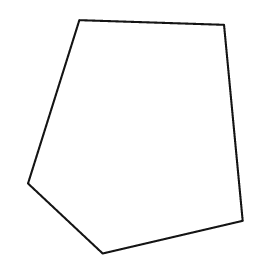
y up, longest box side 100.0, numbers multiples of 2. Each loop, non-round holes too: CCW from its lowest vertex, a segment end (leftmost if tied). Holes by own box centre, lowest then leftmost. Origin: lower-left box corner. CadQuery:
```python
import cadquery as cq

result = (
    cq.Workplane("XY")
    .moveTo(32.0, 0.0)
    .lineTo(92.0, 14.0)
    .lineTo(84.0, 98.0)
    .lineTo(22.0, 100.0)
    .lineTo(0.0, 30.0)
    .close()
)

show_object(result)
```